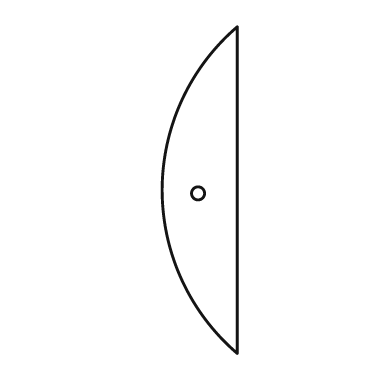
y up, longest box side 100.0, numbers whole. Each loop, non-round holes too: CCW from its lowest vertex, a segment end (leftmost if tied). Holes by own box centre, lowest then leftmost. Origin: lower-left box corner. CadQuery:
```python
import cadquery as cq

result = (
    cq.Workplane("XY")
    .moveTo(23.0, 0.0)
    .lineTo(23.0, 100.0)
    .threePointArc((0.0, 50.0), (23.0, 0.0))
    .close()
    .moveTo(11.0, 49.0)
    .circle(2.0)
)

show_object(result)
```